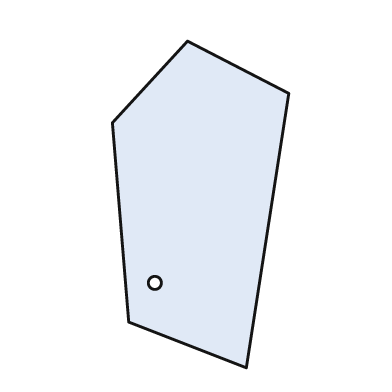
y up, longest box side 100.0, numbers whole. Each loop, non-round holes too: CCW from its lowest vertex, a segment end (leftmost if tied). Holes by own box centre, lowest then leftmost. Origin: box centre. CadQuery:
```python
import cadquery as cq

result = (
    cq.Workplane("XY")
    .moveTo(14.0, -50.0)
    .lineTo(27.0, 34.0)
    .lineTo(-4.0, 50.0)
    .lineTo(-27.0, 25.0)
    .lineTo(-22.0, -36.0)
    .close()
    .moveTo(-14.0, -24.0)
    .circle(2.0)
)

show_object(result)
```